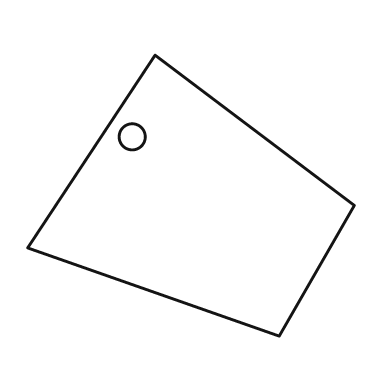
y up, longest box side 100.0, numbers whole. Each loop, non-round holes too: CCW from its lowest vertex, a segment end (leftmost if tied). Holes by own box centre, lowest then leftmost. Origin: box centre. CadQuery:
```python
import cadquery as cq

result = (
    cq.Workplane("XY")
    .moveTo(27.0, -43.0)
    .lineTo(50.0, -3.0)
    .lineTo(-11.0, 43.0)
    .lineTo(-50.0, -16.0)
    .close()
    .moveTo(-18.0, 18.0)
    .circle(4.0)
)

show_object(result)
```